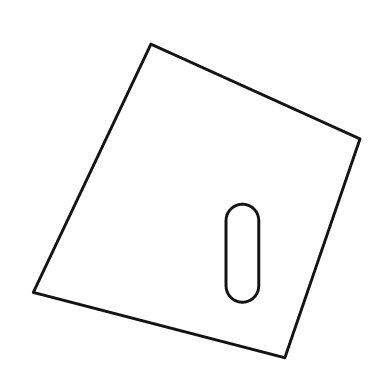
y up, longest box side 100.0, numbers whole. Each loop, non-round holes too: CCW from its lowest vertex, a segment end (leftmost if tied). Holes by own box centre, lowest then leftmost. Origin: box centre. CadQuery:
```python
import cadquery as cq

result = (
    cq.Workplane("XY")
    .moveTo(27.0, -48.0)
    .lineTo(50.0, 19.0)
    .lineTo(-14.0, 48.0)
    .lineTo(-50.0, -28.0)
    .close()
    .moveTo(9.0, -26.0)
    .threePointArc((14.0, -31.0), (19.0, -26.0))
    .lineTo(19.0, -6.0)
    .threePointArc((14.0, -1.0), (9.0, -6.0))
    .close()
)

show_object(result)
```